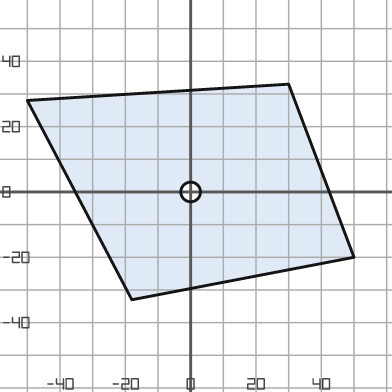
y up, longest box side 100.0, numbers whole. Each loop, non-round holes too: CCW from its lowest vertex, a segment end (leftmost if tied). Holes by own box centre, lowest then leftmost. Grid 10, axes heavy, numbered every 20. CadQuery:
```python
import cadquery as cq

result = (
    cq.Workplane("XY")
    .moveTo(-18.0, -33.0)
    .lineTo(50.0, -20.0)
    .lineTo(30.0, 33.0)
    .lineTo(-50.0, 28.0)
    .close()
    .moveTo(0.0, 0.0)
    .circle(3.0)
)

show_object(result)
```